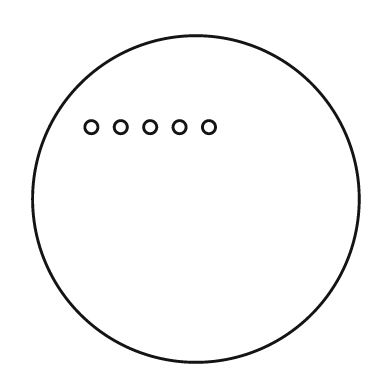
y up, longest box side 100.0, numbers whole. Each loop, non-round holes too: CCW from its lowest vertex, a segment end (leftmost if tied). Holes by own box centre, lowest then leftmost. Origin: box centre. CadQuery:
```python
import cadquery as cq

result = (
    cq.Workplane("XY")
    .moveTo(0.0, 0.0)
    .circle(50.0)
    .moveTo(-32.0, 22.0)
    .circle(2.0)
    .moveTo(-23.0, 22.0)
    .circle(2.0)
    .moveTo(-14.0, 22.0)
    .circle(2.0)
    .moveTo(-5.0, 22.0)
    .circle(2.0)
    .moveTo(4.0, 22.0)
    .circle(2.0)
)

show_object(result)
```